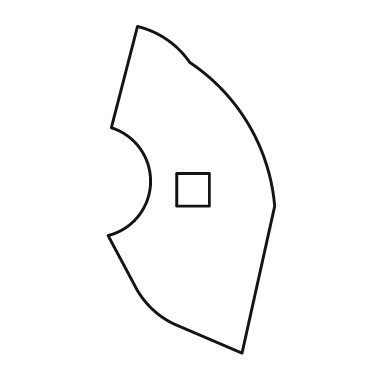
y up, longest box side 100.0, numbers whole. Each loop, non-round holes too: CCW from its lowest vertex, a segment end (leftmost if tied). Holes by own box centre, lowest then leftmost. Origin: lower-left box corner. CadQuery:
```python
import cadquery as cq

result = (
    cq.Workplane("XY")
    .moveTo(41.0, 0.0)
    .lineTo(51.0, 45.0)
    .threePointArc((43.0, 70.0), (25.0, 89.0))
    .threePointArc((18.0, 96.0), (9.0, 100.0))
    .lineTo(1.0, 69.0)
    .threePointArc((13.0, 52.0), (0.0, 36.0))
    .lineTo(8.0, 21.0)
    .threePointArc((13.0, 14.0), (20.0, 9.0))
    .close()
    .moveTo(21.0, 45.0)
    .lineTo(31.0, 45.0)
    .lineTo(31.0, 55.0)
    .lineTo(21.0, 55.0)
    .close()
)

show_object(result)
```